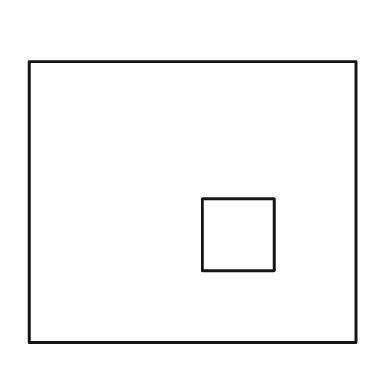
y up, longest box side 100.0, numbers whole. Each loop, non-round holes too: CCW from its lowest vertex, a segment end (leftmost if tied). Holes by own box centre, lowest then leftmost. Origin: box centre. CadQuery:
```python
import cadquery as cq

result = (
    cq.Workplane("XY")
    .moveTo(-50.0, -43.0)
    .lineTo(50.0, -43.0)
    .lineTo(50.0, 43.0)
    .lineTo(-50.0, 43.0)
    .close()
    .moveTo(3.0, -21.0)
    .lineTo(25.0, -21.0)
    .lineTo(25.0, 1.0)
    .lineTo(3.0, 1.0)
    .close()
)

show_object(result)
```